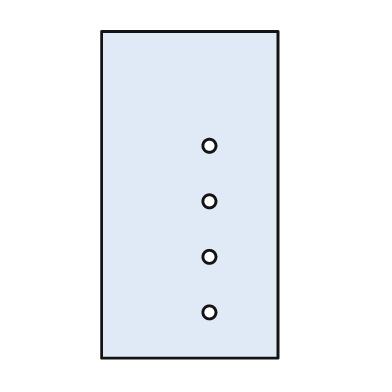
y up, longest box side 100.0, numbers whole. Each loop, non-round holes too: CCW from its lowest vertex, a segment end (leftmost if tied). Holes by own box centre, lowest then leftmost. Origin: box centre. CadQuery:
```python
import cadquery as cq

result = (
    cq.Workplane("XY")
    .moveTo(-27.0, -50.0)
    .lineTo(27.0, -50.0)
    .lineTo(27.0, 50.0)
    .lineTo(-27.0, 50.0)
    .close()
    .moveTo(6.0, -36.0)
    .circle(2.0)
    .moveTo(6.0, -19.0)
    .circle(2.0)
    .moveTo(6.0, -2.0)
    .circle(2.0)
    .moveTo(6.0, 15.0)
    .circle(2.0)
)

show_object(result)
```